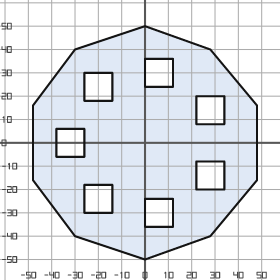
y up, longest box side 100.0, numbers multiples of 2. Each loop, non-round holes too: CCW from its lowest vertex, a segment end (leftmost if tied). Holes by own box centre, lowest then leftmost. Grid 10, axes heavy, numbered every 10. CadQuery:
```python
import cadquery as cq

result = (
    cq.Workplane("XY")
    .moveTo(0.0, -50.0)
    .lineTo(28.0, -40.0)
    .lineTo(48.0, -16.0)
    .lineTo(48.0, 16.0)
    .lineTo(28.0, 40.0)
    .lineTo(0.0, 50.0)
    .lineTo(-30.0, 40.0)
    .lineTo(-48.0, 16.0)
    .lineTo(-48.0, -16.0)
    .lineTo(-30.0, -40.0)
    .close()
    .moveTo(0.0, -36.0)
    .lineTo(12.0, -36.0)
    .lineTo(12.0, -24.0)
    .lineTo(0.0, -24.0)
    .close()
    .moveTo(-26.0, -30.0)
    .lineTo(-14.0, -30.0)
    .lineTo(-14.0, -18.0)
    .lineTo(-26.0, -18.0)
    .close()
    .moveTo(22.0, -20.0)
    .lineTo(34.0, -20.0)
    .lineTo(34.0, -8.0)
    .lineTo(22.0, -8.0)
    .close()
    .moveTo(-38.0, -6.0)
    .lineTo(-26.0, -6.0)
    .lineTo(-26.0, 6.0)
    .lineTo(-38.0, 6.0)
    .close()
    .moveTo(22.0, 8.0)
    .lineTo(34.0, 8.0)
    .lineTo(34.0, 20.0)
    .lineTo(22.0, 20.0)
    .close()
    .moveTo(-26.0, 18.0)
    .lineTo(-14.0, 18.0)
    .lineTo(-14.0, 30.0)
    .lineTo(-26.0, 30.0)
    .close()
    .moveTo(0.0, 24.0)
    .lineTo(12.0, 24.0)
    .lineTo(12.0, 36.0)
    .lineTo(0.0, 36.0)
    .close()
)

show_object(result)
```